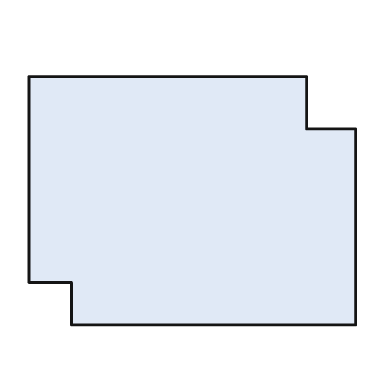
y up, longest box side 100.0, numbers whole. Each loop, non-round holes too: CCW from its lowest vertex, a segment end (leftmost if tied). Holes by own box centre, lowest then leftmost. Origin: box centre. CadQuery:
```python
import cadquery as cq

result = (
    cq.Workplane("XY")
    .moveTo(-37.0, -38.0)
    .lineTo(50.0, -38.0)
    .lineTo(50.0, 22.0)
    .lineTo(35.0, 22.0)
    .lineTo(35.0, 38.0)
    .lineTo(-50.0, 38.0)
    .lineTo(-50.0, -25.0)
    .lineTo(-37.0, -25.0)
    .close()
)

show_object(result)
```